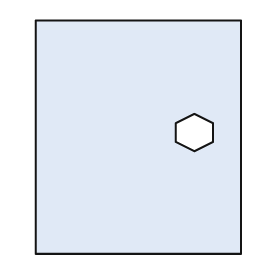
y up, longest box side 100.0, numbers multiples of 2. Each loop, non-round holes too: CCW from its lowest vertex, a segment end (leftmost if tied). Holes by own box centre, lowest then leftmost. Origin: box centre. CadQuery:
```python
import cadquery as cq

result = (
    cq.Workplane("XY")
    .moveTo(-44.0, -50.0)
    .lineTo(44.0, -50.0)
    .lineTo(44.0, 50.0)
    .lineTo(-44.0, 50.0)
    .close()
    .moveTo(24.0, -6.0)
    .lineTo(32.0, -2.0)
    .lineTo(32.0, 6.0)
    .lineTo(24.0, 10.0)
    .lineTo(16.0, 6.0)
    .lineTo(16.0, -2.0)
    .close()
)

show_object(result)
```